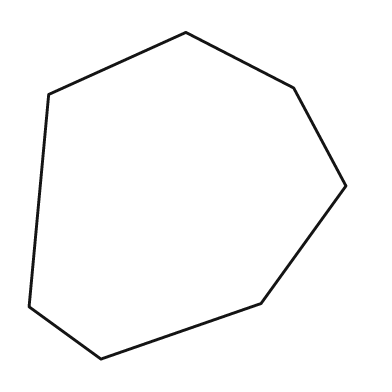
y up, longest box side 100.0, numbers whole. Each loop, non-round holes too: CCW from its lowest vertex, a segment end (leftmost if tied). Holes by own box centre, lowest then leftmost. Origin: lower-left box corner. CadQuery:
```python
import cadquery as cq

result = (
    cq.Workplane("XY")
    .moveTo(22.0, 0.0)
    .lineTo(71.0, 17.0)
    .lineTo(97.0, 53.0)
    .lineTo(81.0, 83.0)
    .lineTo(48.0, 100.0)
    .lineTo(6.0, 81.0)
    .lineTo(0.0, 16.0)
    .close()
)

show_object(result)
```